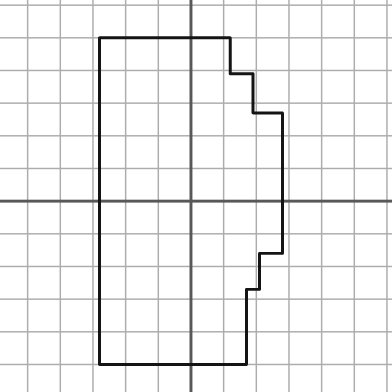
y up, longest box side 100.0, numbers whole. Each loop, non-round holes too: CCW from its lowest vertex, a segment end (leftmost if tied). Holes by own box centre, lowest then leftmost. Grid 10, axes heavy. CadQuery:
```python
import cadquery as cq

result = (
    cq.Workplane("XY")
    .moveTo(-28.0, -50.0)
    .lineTo(17.0, -50.0)
    .lineTo(17.0, -27.0)
    .lineTo(21.0, -27.0)
    .lineTo(21.0, -16.0)
    .lineTo(28.0, -16.0)
    .lineTo(28.0, 27.0)
    .lineTo(19.0, 27.0)
    .lineTo(19.0, 39.0)
    .lineTo(12.0, 39.0)
    .lineTo(12.0, 50.0)
    .lineTo(-28.0, 50.0)
    .close()
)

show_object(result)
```